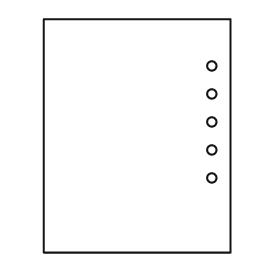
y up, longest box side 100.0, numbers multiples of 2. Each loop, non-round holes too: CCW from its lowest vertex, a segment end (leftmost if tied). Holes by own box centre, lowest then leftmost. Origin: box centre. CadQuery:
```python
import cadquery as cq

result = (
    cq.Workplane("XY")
    .moveTo(-40.0, -50.0)
    .lineTo(40.0, -50.0)
    .lineTo(40.0, 50.0)
    .lineTo(-40.0, 50.0)
    .close()
    .moveTo(32.0, -18.0)
    .circle(2.0)
    .moveTo(32.0, -6.0)
    .circle(2.0)
    .moveTo(32.0, 6.0)
    .circle(2.0)
    .moveTo(32.0, 18.0)
    .circle(2.0)
    .moveTo(32.0, 30.0)
    .circle(2.0)
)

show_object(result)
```